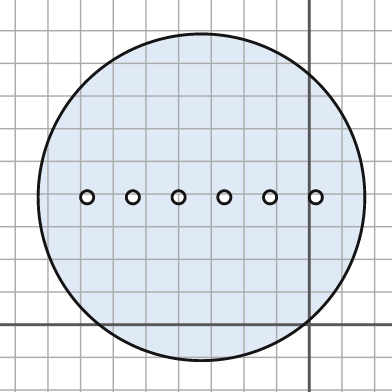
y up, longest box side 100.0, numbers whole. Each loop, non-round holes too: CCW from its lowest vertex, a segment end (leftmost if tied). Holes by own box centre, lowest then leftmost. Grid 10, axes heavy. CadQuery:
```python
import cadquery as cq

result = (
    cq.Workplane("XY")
    .moveTo(-33.0, 39.0)
    .circle(50.0)
    .moveTo(-68.0, 39.0)
    .circle(2.0)
    .moveTo(-54.0, 39.0)
    .circle(2.0)
    .moveTo(-40.0, 39.0)
    .circle(2.0)
    .moveTo(-26.0, 39.0)
    .circle(2.0)
    .moveTo(-12.0, 39.0)
    .circle(2.0)
    .moveTo(2.0, 39.0)
    .circle(2.0)
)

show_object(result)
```